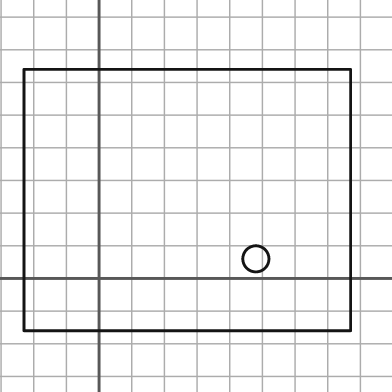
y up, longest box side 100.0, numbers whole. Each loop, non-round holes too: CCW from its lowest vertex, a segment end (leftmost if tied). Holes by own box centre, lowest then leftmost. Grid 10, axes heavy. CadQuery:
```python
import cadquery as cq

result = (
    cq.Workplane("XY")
    .moveTo(-23.0, -16.0)
    .lineTo(77.0, -16.0)
    .lineTo(77.0, 64.0)
    .lineTo(-23.0, 64.0)
    .close()
    .moveTo(48.0, 6.0)
    .circle(4.0)
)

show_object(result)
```